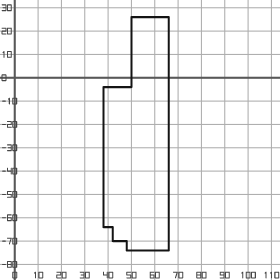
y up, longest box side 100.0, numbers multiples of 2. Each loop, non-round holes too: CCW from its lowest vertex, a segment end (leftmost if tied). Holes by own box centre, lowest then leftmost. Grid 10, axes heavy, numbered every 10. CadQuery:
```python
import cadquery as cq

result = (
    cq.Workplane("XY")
    .moveTo(48.0, -74.0)
    .lineTo(66.0, -74.0)
    .lineTo(66.0, 26.0)
    .lineTo(50.0, 26.0)
    .lineTo(50.0, -4.0)
    .lineTo(38.0, -4.0)
    .lineTo(38.0, -64.0)
    .lineTo(42.0, -64.0)
    .lineTo(42.0, -70.0)
    .lineTo(48.0, -70.0)
    .close()
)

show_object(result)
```